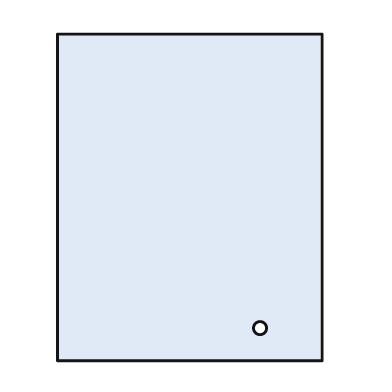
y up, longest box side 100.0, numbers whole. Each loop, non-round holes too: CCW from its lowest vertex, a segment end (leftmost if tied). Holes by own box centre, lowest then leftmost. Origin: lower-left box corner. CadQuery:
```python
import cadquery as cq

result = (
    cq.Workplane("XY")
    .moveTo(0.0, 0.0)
    .lineTo(81.0, 0.0)
    .lineTo(81.0, 100.0)
    .lineTo(0.0, 100.0)
    .close()
    .moveTo(62.0, 10.0)
    .circle(2.0)
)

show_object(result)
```